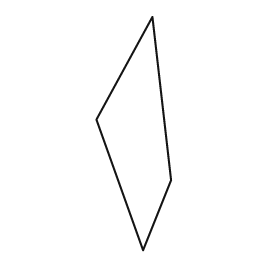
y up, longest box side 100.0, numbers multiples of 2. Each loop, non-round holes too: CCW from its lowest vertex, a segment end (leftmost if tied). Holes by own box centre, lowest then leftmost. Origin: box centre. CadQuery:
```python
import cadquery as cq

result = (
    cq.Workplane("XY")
    .moveTo(4.0, -50.0)
    .lineTo(16.0, -20.0)
    .lineTo(8.0, 50.0)
    .lineTo(-16.0, 6.0)
    .close()
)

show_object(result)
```